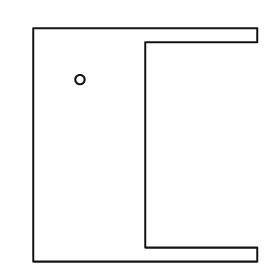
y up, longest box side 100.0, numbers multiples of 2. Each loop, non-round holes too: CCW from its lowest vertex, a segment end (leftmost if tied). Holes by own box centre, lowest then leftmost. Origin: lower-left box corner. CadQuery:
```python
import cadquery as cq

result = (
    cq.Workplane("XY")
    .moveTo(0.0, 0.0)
    .lineTo(96.0, 0.0)
    .lineTo(96.0, 6.0)
    .lineTo(48.0, 6.0)
    .lineTo(48.0, 94.0)
    .lineTo(96.0, 94.0)
    .lineTo(96.0, 100.0)
    .lineTo(0.0, 100.0)
    .close()
    .moveTo(20.0, 78.0)
    .circle(2.0)
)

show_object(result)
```